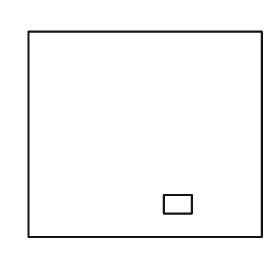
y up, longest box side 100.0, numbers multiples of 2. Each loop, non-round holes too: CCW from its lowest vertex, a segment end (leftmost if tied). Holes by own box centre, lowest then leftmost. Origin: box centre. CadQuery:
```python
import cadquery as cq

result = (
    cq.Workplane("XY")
    .moveTo(-50.0, -44.0)
    .lineTo(50.0, -44.0)
    .lineTo(50.0, 44.0)
    .lineTo(-50.0, 44.0)
    .close()
    .moveTo(8.0, -34.0)
    .lineTo(20.0, -34.0)
    .lineTo(20.0, -26.0)
    .lineTo(8.0, -26.0)
    .close()
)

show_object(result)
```